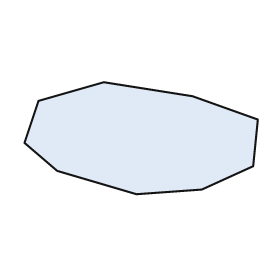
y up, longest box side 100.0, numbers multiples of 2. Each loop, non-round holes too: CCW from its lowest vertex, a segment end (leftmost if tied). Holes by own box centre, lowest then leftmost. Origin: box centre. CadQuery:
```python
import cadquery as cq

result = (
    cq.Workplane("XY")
    .moveTo(-2.0, -24.0)
    .lineTo(26.0, -22.0)
    .lineTo(48.0, -12.0)
    .lineTo(50.0, 8.0)
    .lineTo(22.0, 18.0)
    .lineTo(-16.0, 24.0)
    .lineTo(-44.0, 16.0)
    .lineTo(-50.0, -2.0)
    .lineTo(-36.0, -14.0)
    .close()
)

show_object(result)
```